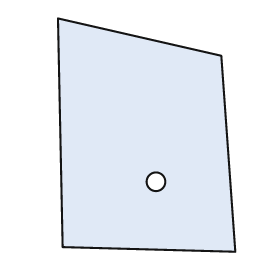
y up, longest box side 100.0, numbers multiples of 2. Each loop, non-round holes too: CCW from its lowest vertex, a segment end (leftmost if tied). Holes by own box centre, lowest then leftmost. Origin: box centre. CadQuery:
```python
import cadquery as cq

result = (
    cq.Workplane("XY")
    .moveTo(38.0, -50.0)
    .lineTo(32.0, 34.0)
    .lineTo(-38.0, 50.0)
    .lineTo(-36.0, -48.0)
    .close()
    .moveTo(4.0, -20.0)
    .circle(4.0)
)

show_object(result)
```